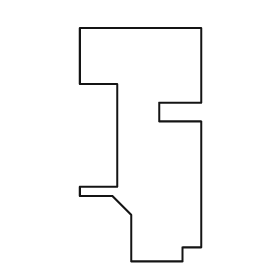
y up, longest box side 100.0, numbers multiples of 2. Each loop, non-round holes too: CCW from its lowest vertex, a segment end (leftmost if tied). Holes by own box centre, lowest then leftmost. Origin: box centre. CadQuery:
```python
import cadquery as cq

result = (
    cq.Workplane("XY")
    .moveTo(-4.0, -50.0)
    .lineTo(18.0, -50.0)
    .lineTo(18.0, -44.0)
    .lineTo(26.0, -44.0)
    .lineTo(26.0, 10.0)
    .lineTo(8.0, 10.0)
    .lineTo(8.0, 18.0)
    .lineTo(26.0, 18.0)
    .lineTo(26.0, 50.0)
    .lineTo(-26.0, 50.0)
    .lineTo(-26.0, 26.0)
    .lineTo(-10.0, 26.0)
    .lineTo(-10.0, -18.0)
    .lineTo(-26.0, -18.0)
    .lineTo(-26.0, -22.0)
    .lineTo(-12.0, -22.0)
    .lineTo(-4.0, -30.0)
    .close()
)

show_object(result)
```